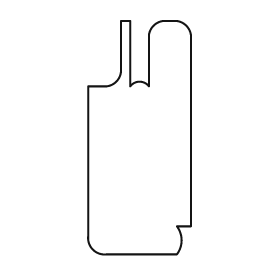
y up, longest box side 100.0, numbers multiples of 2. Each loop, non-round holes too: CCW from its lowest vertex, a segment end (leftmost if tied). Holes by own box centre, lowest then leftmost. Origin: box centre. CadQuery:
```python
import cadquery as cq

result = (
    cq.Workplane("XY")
    .moveTo(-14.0, -50.0)
    .lineTo(16.0, -50.0)
    .threePointArc((18.0, -44.0), (16.0, -38.0))
    .lineTo(22.0, -38.0)
    .lineTo(22.0, 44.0)
    .threePointArc((20.0, 48.0), (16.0, 50.0))
    .lineTo(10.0, 50.0)
    .threePointArc((6.0, 48.0), (4.0, 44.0))
    .lineTo(4.0, 22.0)
    .threePointArc((0.0, 24.0), (-4.0, 22.0))
    .lineTo(-4.0, 50.0)
    .lineTo(-8.0, 50.0)
    .lineTo(-8.0, 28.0)
    .threePointArc((-10.0, 24.0), (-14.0, 22.0))
    .lineTo(-22.0, 22.0)
    .lineTo(-22.0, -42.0)
    .threePointArc((-20.0, -48.0), (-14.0, -50.0))
    .close()
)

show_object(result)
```